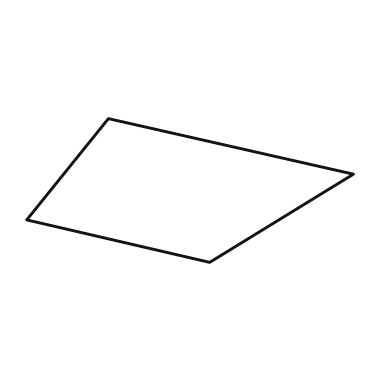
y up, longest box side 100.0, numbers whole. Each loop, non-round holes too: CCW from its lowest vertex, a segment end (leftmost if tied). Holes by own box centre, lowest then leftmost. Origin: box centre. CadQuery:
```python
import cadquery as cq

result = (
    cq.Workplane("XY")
    .moveTo(6.0, -22.0)
    .lineTo(50.0, 5.0)
    .lineTo(-25.0, 22.0)
    .lineTo(-50.0, -9.0)
    .close()
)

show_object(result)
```